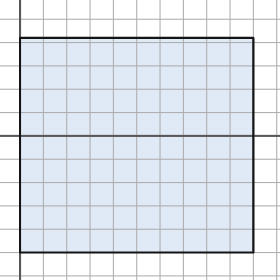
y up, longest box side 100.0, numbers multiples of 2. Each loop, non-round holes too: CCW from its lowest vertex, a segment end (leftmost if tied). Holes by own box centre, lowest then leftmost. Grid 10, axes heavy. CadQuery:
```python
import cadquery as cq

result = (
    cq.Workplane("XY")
    .moveTo(0.0, -50.0)
    .lineTo(100.0, -50.0)
    .lineTo(100.0, 42.0)
    .lineTo(0.0, 42.0)
    .close()
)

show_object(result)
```